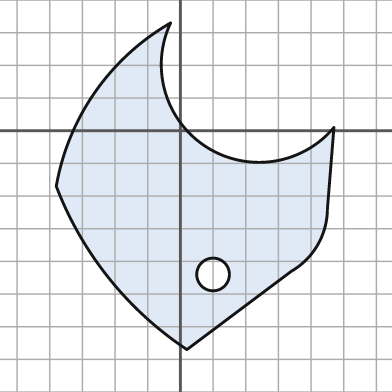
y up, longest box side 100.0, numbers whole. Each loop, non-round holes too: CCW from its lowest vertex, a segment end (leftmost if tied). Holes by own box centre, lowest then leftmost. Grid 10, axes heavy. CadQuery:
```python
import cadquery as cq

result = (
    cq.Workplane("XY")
    .moveTo(2.0, -67.0)
    .lineTo(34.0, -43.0)
    .threePointArc((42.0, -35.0), (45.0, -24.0))
    .lineTo(47.0, 1.0)
    .threePointArc((8.0, -5.0), (-3.0, 33.0))
    .threePointArc((-26.0, 12.0), (-38.0, -17.0))
    .threePointArc((-22.0, -45.0), (2.0, -67.0))
    .close()
    .moveTo(10.0, -44.0)
    .circle(5.0)
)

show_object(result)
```